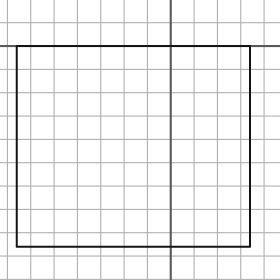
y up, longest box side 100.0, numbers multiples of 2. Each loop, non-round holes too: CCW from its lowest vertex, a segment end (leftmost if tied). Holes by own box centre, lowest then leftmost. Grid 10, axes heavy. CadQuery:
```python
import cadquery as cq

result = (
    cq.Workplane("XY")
    .moveTo(-66.0, -86.0)
    .lineTo(34.0, -86.0)
    .lineTo(34.0, 0.0)
    .lineTo(-66.0, 0.0)
    .close()
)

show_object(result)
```